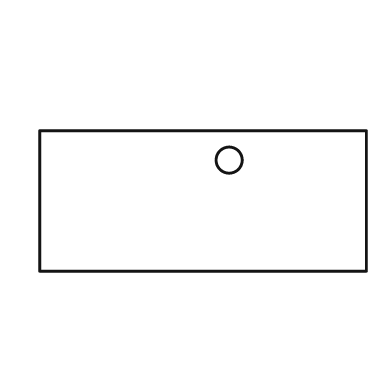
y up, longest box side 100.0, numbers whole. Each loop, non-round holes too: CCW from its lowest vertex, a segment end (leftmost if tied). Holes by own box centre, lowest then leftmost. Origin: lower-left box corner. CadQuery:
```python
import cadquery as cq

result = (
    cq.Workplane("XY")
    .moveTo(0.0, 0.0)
    .lineTo(100.0, 0.0)
    .lineTo(100.0, 43.0)
    .lineTo(0.0, 43.0)
    .close()
    .moveTo(58.0, 34.0)
    .circle(4.0)
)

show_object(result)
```